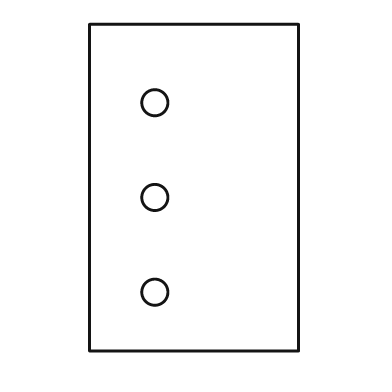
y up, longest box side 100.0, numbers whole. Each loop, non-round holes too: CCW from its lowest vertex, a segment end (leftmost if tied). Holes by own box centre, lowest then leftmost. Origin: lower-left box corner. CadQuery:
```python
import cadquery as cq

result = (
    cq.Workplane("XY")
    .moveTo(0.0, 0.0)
    .lineTo(64.0, 0.0)
    .lineTo(64.0, 100.0)
    .lineTo(0.0, 100.0)
    .close()
    .moveTo(20.0, 18.0)
    .circle(4.0)
    .moveTo(20.0, 47.0)
    .circle(4.0)
    .moveTo(20.0, 76.0)
    .circle(4.0)
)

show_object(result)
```